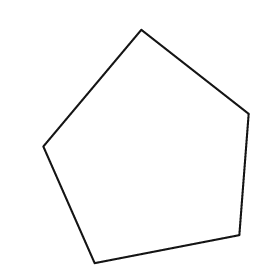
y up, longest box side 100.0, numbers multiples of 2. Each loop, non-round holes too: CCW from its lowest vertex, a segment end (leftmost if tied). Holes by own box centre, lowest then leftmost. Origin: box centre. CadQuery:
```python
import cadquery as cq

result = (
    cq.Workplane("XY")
    .moveTo(-22.0, -50.0)
    .lineTo(40.0, -38.0)
    .lineTo(44.0, 14.0)
    .lineTo(-2.0, 50.0)
    .lineTo(-44.0, 0.0)
    .close()
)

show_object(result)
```